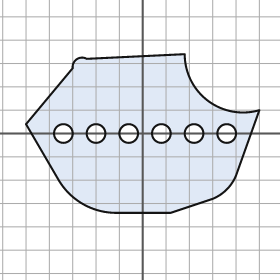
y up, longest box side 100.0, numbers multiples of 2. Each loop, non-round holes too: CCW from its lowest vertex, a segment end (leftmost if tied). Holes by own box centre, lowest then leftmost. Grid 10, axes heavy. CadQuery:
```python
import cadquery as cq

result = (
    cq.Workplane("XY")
    .moveTo(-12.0, -34.0)
    .lineTo(12.0, -34.0)
    .lineTo(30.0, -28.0)
    .threePointArc((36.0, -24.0), (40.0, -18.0))
    .lineTo(50.0, 10.0)
    .threePointArc((28.0, 14.0), (18.0, 34.0))
    .lineTo(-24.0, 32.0)
    .threePointArc((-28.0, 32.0), (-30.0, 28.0))
    .lineTo(-50.0, 4.0)
    .lineTo(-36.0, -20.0)
    .threePointArc((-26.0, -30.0), (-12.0, -34.0))
    .close()
    .moveTo(-34.0, 0.0)
    .circle(4.0)
    .moveTo(-20.0, 0.0)
    .circle(4.0)
    .moveTo(-6.0, 0.0)
    .circle(4.0)
    .moveTo(8.0, 0.0)
    .circle(4.0)
    .moveTo(22.0, 0.0)
    .circle(4.0)
    .moveTo(36.0, 0.0)
    .circle(4.0)
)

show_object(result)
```